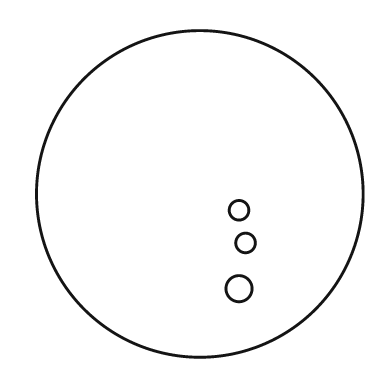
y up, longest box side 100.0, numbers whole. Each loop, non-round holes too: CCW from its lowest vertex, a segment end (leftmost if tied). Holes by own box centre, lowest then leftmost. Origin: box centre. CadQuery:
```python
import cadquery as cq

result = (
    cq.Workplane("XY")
    .moveTo(0.0, 0.0)
    .circle(50.0)
    .moveTo(12.0, -29.0)
    .circle(4.0)
    .moveTo(14.0, -15.0)
    .circle(3.0)
    .moveTo(12.0, -5.0)
    .circle(3.0)
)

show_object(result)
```